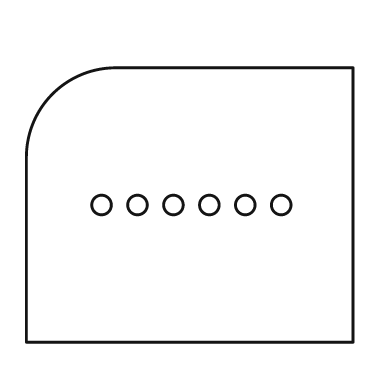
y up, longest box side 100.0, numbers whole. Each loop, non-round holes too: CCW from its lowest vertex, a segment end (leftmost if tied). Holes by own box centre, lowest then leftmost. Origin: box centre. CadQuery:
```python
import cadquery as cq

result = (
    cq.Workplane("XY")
    .moveTo(-50.0, -42.0)
    .lineTo(50.0, -42.0)
    .lineTo(50.0, 42.0)
    .lineTo(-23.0, 42.0)
    .threePointArc((-42.0, 34.0), (-50.0, 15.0))
    .close()
    .moveTo(-27.0, 0.0)
    .circle(3.0)
    .moveTo(-16.0, 0.0)
    .circle(3.0)
    .moveTo(-5.0, 0.0)
    .circle(3.0)
    .moveTo(6.0, 0.0)
    .circle(3.0)
    .moveTo(17.0, 0.0)
    .circle(3.0)
    .moveTo(28.0, 0.0)
    .circle(3.0)
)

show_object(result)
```